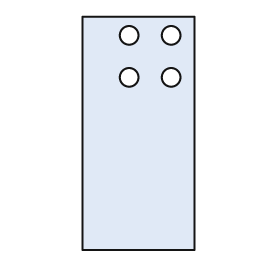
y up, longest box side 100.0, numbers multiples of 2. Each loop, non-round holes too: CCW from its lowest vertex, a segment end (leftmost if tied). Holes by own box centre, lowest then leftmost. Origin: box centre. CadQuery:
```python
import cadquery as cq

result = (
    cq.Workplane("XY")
    .moveTo(-24.0, -50.0)
    .lineTo(24.0, -50.0)
    .lineTo(24.0, 50.0)
    .lineTo(-24.0, 50.0)
    .close()
    .moveTo(-4.0, 24.0)
    .circle(4.0)
    .moveTo(14.0, 24.0)
    .circle(4.0)
    .moveTo(-4.0, 42.0)
    .circle(4.0)
    .moveTo(14.0, 42.0)
    .circle(4.0)
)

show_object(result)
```